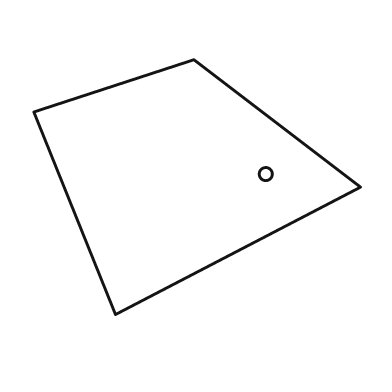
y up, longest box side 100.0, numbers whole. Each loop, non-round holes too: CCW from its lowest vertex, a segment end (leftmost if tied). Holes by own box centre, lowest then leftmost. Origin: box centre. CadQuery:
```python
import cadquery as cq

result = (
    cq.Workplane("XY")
    .moveTo(-25.0, -39.0)
    .lineTo(50.0, 0.0)
    .lineTo(-1.0, 39.0)
    .lineTo(-50.0, 23.0)
    .close()
    .moveTo(21.0, 4.0)
    .circle(2.0)
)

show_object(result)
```